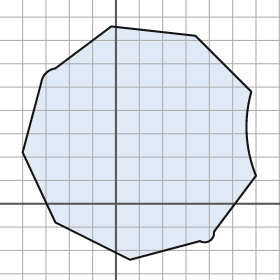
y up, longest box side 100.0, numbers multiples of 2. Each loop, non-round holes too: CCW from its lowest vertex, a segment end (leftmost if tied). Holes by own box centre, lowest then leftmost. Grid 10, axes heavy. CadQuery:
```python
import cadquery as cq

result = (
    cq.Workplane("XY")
    .moveTo(6.0, -24.0)
    .lineTo(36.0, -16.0)
    .threePointArc((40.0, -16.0), (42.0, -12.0))
    .lineTo(60.0, 12.0)
    .threePointArc((56.0, 30.0), (58.0, 48.0))
    .lineTo(34.0, 72.0)
    .lineTo(-2.0, 76.0)
    .lineTo(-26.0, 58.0)
    .threePointArc((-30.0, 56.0), (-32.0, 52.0))
    .lineTo(-40.0, 22.0)
    .lineTo(-26.0, -8.0)
    .close()
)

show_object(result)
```